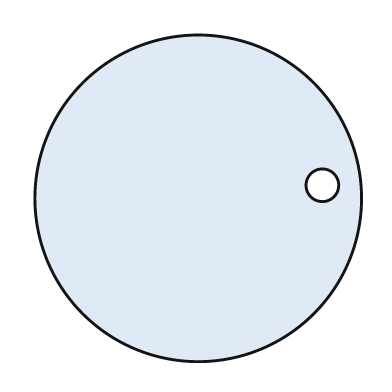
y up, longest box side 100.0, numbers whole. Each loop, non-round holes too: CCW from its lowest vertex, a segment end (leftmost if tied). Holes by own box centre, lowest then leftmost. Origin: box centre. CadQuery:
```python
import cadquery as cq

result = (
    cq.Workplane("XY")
    .moveTo(0.0, 0.0)
    .circle(50.0)
    .moveTo(38.0, 4.0)
    .circle(5.0)
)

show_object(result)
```